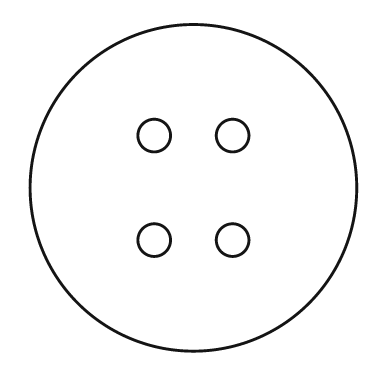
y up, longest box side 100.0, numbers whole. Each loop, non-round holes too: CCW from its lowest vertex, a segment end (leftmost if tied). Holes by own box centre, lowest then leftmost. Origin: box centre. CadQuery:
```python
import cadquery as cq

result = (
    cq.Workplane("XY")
    .moveTo(0.0, 0.0)
    .circle(50.0)
    .moveTo(-12.0, -16.0)
    .circle(5.0)
    .moveTo(12.0, -16.0)
    .circle(5.0)
    .moveTo(-12.0, 16.0)
    .circle(5.0)
    .moveTo(12.0, 16.0)
    .circle(5.0)
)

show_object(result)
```